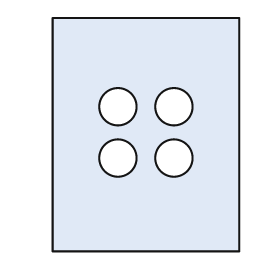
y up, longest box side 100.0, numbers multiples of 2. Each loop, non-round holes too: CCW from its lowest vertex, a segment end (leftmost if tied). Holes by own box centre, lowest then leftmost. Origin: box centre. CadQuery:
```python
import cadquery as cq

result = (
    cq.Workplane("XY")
    .moveTo(-40.0, -50.0)
    .lineTo(40.0, -50.0)
    .lineTo(40.0, 50.0)
    .lineTo(-40.0, 50.0)
    .close()
    .moveTo(-12.0, -10.0)
    .circle(8.0)
    .moveTo(12.0, -10.0)
    .circle(8.0)
    .moveTo(-12.0, 12.0)
    .circle(8.0)
    .moveTo(12.0, 12.0)
    .circle(8.0)
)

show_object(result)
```